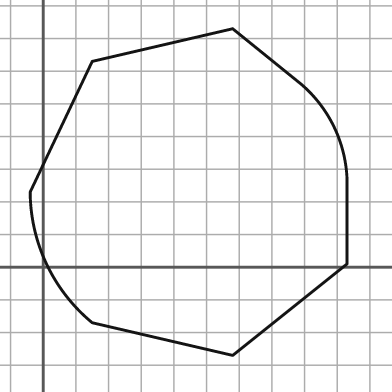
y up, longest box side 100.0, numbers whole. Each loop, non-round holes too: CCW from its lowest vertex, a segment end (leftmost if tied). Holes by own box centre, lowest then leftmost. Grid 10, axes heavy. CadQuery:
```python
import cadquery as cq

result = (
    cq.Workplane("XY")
    .moveTo(58.0, -27.0)
    .lineTo(93.0, 1.0)
    .lineTo(93.0, 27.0)
    .threePointArc((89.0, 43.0), (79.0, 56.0))
    .lineTo(58.0, 73.0)
    .lineTo(15.0, 63.0)
    .lineTo(-4.0, 23.0)
    .threePointArc((1.0, 1.0), (15.0, -17.0))
    .close()
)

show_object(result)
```